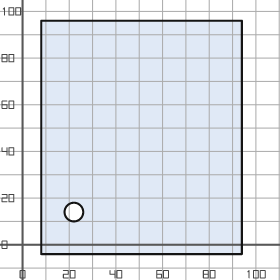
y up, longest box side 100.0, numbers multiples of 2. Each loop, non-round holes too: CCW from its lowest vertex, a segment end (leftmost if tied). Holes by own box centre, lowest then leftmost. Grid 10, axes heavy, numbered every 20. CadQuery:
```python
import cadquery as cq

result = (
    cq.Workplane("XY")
    .moveTo(8.0, -4.0)
    .lineTo(94.0, -4.0)
    .lineTo(94.0, 96.0)
    .lineTo(8.0, 96.0)
    .close()
    .moveTo(22.0, 14.0)
    .circle(4.0)
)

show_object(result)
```